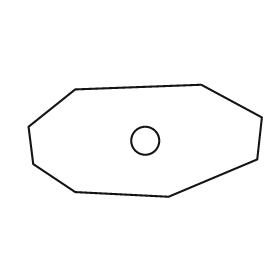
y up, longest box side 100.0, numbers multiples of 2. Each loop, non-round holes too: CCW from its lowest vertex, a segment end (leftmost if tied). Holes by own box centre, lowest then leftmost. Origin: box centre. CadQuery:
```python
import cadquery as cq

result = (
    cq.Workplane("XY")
    .moveTo(10.0, -24.0)
    .lineTo(48.0, -8.0)
    .lineTo(50.0, 10.0)
    .lineTo(24.0, 24.0)
    .lineTo(-30.0, 22.0)
    .lineTo(-50.0, 6.0)
    .lineTo(-48.0, -10.0)
    .lineTo(-30.0, -22.0)
    .close()
    .moveTo(0.0, 0.0)
    .circle(6.0)
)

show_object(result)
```